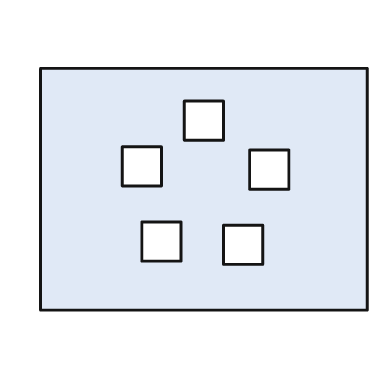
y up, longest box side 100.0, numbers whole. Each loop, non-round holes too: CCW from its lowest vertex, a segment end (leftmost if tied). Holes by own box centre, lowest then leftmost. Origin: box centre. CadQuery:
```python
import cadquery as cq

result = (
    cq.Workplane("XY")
    .moveTo(-50.0, -37.0)
    .lineTo(50.0, -37.0)
    .lineTo(50.0, 37.0)
    .lineTo(-50.0, 37.0)
    .close()
    .moveTo(6.0, -23.0)
    .lineTo(18.0, -23.0)
    .lineTo(18.0, -11.0)
    .lineTo(6.0, -11.0)
    .close()
    .moveTo(-19.0, -22.0)
    .lineTo(-7.0, -22.0)
    .lineTo(-7.0, -10.0)
    .lineTo(-19.0, -10.0)
    .close()
    .moveTo(14.0, 0.0)
    .lineTo(26.0, 0.0)
    .lineTo(26.0, 12.0)
    .lineTo(14.0, 12.0)
    .close()
    .moveTo(-25.0, 1.0)
    .lineTo(-13.0, 1.0)
    .lineTo(-13.0, 13.0)
    .lineTo(-25.0, 13.0)
    .close()
    .moveTo(-6.0, 15.0)
    .lineTo(6.0, 15.0)
    .lineTo(6.0, 27.0)
    .lineTo(-6.0, 27.0)
    .close()
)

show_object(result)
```